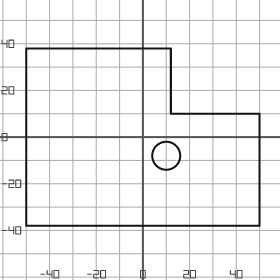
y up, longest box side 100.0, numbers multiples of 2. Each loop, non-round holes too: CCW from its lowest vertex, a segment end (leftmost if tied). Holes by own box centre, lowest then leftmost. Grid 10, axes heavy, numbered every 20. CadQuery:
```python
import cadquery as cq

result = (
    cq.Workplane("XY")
    .moveTo(-50.0, -38.0)
    .lineTo(50.0, -38.0)
    .lineTo(50.0, 10.0)
    .lineTo(12.0, 10.0)
    .lineTo(12.0, 38.0)
    .lineTo(-50.0, 38.0)
    .close()
    .moveTo(10.0, -8.0)
    .circle(6.0)
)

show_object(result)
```